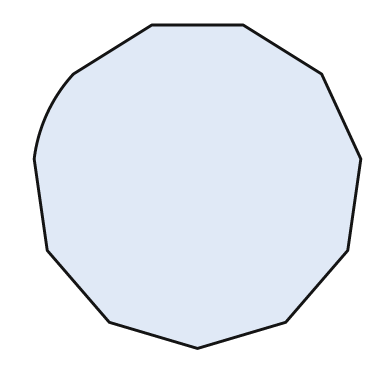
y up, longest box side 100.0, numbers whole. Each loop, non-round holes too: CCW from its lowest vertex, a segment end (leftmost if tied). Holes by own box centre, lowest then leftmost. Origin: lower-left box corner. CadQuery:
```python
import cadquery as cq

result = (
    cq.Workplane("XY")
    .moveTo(50.0, 0.0)
    .lineTo(77.0, 8.0)
    .lineTo(96.0, 30.0)
    .lineTo(100.0, 58.0)
    .lineTo(88.0, 84.0)
    .lineTo(64.0, 99.0)
    .lineTo(36.0, 99.0)
    .lineTo(12.0, 84.0)
    .threePointArc((4.0, 72.0), (0.0, 58.0))
    .lineTo(4.0, 30.0)
    .lineTo(23.0, 8.0)
    .close()
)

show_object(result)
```